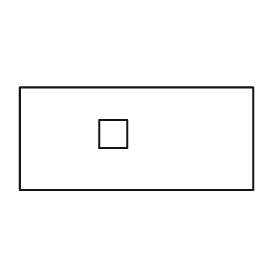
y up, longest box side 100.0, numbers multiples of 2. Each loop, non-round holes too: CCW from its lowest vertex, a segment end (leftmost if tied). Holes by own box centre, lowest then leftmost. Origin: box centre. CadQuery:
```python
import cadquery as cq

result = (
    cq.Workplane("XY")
    .moveTo(-50.0, -22.0)
    .lineTo(50.0, -22.0)
    .lineTo(50.0, 22.0)
    .lineTo(-50.0, 22.0)
    .close()
    .moveTo(-16.0, -4.0)
    .lineTo(-4.0, -4.0)
    .lineTo(-4.0, 8.0)
    .lineTo(-16.0, 8.0)
    .close()
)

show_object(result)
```